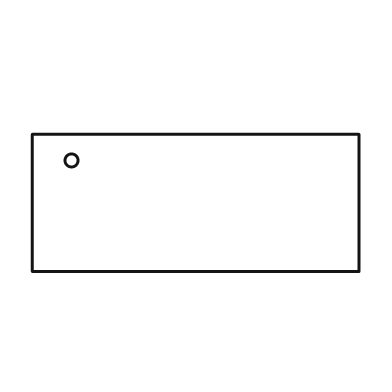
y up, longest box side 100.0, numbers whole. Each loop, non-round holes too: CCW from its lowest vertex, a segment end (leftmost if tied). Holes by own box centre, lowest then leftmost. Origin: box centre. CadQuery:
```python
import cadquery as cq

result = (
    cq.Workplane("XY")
    .moveTo(-50.0, -21.0)
    .lineTo(50.0, -21.0)
    .lineTo(50.0, 21.0)
    .lineTo(-50.0, 21.0)
    .close()
    .moveTo(-38.0, 13.0)
    .circle(2.0)
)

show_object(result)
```